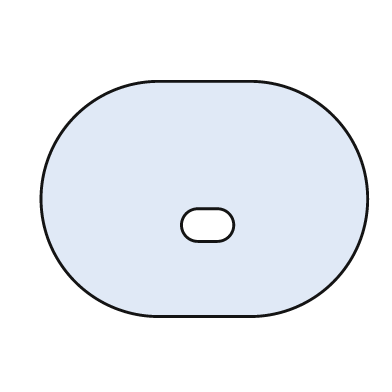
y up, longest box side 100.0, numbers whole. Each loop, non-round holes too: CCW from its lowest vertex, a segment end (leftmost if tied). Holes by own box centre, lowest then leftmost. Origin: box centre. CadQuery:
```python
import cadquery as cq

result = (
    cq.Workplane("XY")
    .moveTo(-14.0, -36.0)
    .lineTo(14.0, -36.0)
    .threePointArc((50.0, 0.0), (14.0, 36.0))
    .lineTo(-14.0, 36.0)
    .threePointArc((-50.0, 0.0), (-14.0, -36.0))
    .close()
    .moveTo(-2.0, -13.0)
    .lineTo(4.0, -13.0)
    .threePointArc((9.0, -8.0), (4.0, -3.0))
    .lineTo(-2.0, -3.0)
    .threePointArc((-7.0, -8.0), (-2.0, -13.0))
    .close()
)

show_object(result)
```